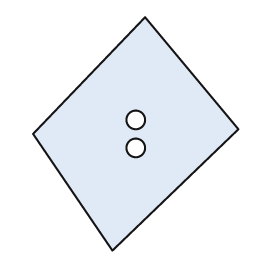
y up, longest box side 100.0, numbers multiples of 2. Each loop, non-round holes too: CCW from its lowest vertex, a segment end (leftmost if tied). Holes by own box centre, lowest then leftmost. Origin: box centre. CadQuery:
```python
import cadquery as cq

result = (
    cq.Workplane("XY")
    .moveTo(-10.0, -50.0)
    .lineTo(44.0, 2.0)
    .lineTo(4.0, 50.0)
    .lineTo(-44.0, 0.0)
    .close()
    .moveTo(0.0, -6.0)
    .circle(4.0)
    .moveTo(0.0, 6.0)
    .circle(4.0)
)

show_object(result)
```